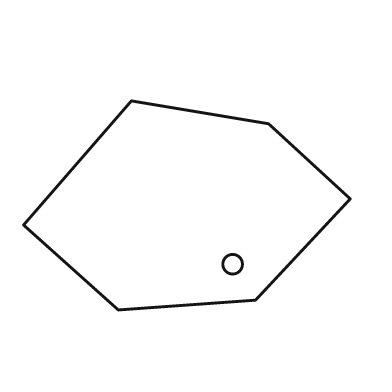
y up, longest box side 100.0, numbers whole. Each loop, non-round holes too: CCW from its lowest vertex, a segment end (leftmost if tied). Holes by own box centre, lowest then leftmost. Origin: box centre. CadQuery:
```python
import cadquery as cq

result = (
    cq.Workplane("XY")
    .moveTo(-21.0, -32.0)
    .lineTo(21.0, -29.0)
    .lineTo(50.0, 2.0)
    .lineTo(25.0, 25.0)
    .lineTo(-17.0, 32.0)
    .lineTo(-50.0, -6.0)
    .close()
    .moveTo(14.0, -18.0)
    .circle(3.0)
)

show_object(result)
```